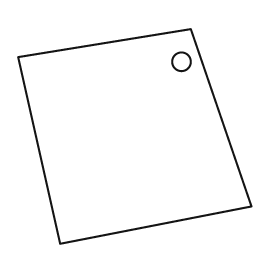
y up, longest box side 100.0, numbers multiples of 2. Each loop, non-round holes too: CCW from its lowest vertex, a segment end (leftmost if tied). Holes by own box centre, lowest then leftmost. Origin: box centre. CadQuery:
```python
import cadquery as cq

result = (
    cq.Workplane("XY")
    .moveTo(-32.0, -46.0)
    .lineTo(50.0, -30.0)
    .lineTo(24.0, 46.0)
    .lineTo(-50.0, 34.0)
    .close()
    .moveTo(20.0, 32.0)
    .circle(4.0)
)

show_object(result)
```